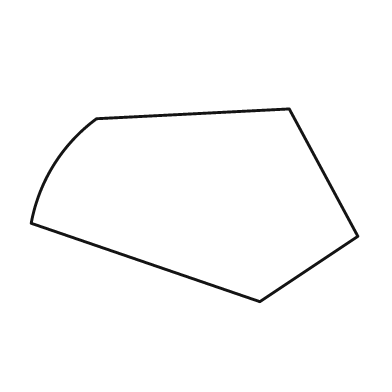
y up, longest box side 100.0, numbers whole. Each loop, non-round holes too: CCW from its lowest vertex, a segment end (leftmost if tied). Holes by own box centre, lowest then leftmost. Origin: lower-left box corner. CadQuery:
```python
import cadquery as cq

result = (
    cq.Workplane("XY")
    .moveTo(70.0, 0.0)
    .lineTo(100.0, 20.0)
    .lineTo(79.0, 59.0)
    .lineTo(20.0, 56.0)
    .threePointArc((7.0, 42.0), (0.0, 24.0))
    .close()
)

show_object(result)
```